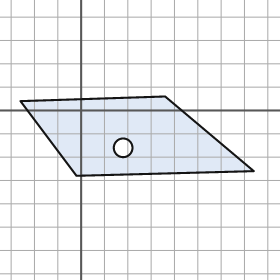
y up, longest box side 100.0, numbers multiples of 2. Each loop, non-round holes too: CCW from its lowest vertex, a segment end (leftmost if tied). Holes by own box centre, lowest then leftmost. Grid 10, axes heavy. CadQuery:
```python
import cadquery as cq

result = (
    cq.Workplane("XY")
    .moveTo(-2.0, -28.0)
    .lineTo(74.0, -26.0)
    .lineTo(36.0, 6.0)
    .lineTo(-26.0, 4.0)
    .close()
    .moveTo(18.0, -16.0)
    .circle(4.0)
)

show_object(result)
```